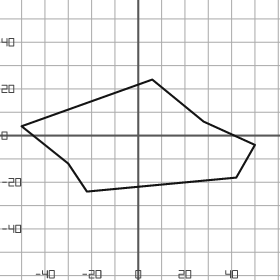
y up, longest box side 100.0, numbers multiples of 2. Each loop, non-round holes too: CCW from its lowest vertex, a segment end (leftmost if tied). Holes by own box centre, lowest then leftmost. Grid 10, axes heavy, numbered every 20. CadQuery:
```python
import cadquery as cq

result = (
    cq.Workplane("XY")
    .moveTo(-22.0, -24.0)
    .lineTo(42.0, -18.0)
    .lineTo(50.0, -4.0)
    .lineTo(28.0, 6.0)
    .lineTo(6.0, 24.0)
    .lineTo(-50.0, 4.0)
    .lineTo(-30.0, -12.0)
    .close()
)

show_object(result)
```